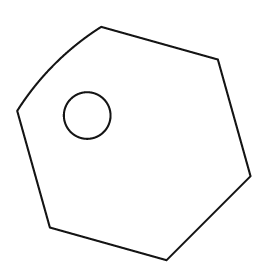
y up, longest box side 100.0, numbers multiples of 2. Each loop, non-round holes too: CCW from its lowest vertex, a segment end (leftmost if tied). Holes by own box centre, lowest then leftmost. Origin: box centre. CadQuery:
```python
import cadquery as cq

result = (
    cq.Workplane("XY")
    .moveTo(14.0, -50.0)
    .lineTo(50.0, -14.0)
    .lineTo(36.0, 36.0)
    .lineTo(-14.0, 50.0)
    .threePointArc((-34.0, 34.0), (-50.0, 14.0))
    .lineTo(-36.0, -36.0)
    .close()
    .moveTo(-20.0, 12.0)
    .circle(10.0)
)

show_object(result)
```